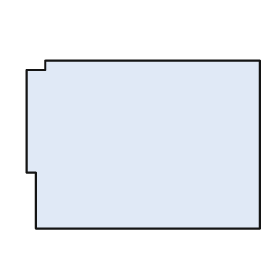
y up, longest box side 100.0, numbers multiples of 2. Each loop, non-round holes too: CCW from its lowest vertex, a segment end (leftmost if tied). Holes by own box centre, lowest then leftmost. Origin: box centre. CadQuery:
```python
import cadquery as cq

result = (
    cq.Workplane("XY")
    .moveTo(-46.0, -36.0)
    .lineTo(50.0, -36.0)
    .lineTo(50.0, 36.0)
    .lineTo(-42.0, 36.0)
    .lineTo(-42.0, 32.0)
    .lineTo(-50.0, 32.0)
    .lineTo(-50.0, -12.0)
    .lineTo(-46.0, -12.0)
    .close()
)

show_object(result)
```